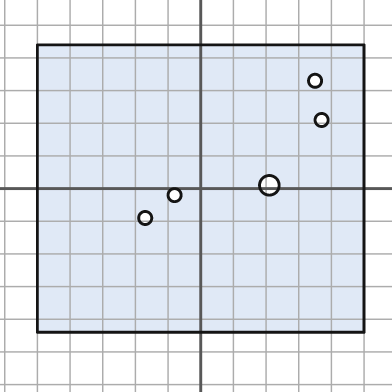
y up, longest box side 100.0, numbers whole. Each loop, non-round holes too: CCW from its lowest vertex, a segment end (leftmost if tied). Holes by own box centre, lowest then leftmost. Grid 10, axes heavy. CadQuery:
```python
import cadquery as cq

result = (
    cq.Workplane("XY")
    .moveTo(-50.0, -44.0)
    .lineTo(50.0, -44.0)
    .lineTo(50.0, 44.0)
    .lineTo(-50.0, 44.0)
    .close()
    .moveTo(-17.0, -9.0)
    .circle(2.0)
    .moveTo(-8.0, -2.0)
    .circle(2.0)
    .moveTo(21.0, 1.0)
    .circle(3.0)
    .moveTo(37.0, 21.0)
    .circle(2.0)
    .moveTo(35.0, 33.0)
    .circle(2.0)
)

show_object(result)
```